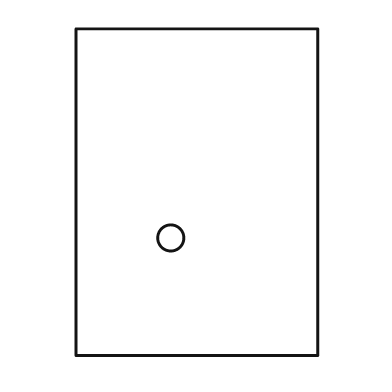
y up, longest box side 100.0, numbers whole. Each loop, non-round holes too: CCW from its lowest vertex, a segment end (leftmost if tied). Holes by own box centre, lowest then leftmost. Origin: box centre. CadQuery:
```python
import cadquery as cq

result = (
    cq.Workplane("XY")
    .moveTo(-37.0, -50.0)
    .lineTo(37.0, -50.0)
    .lineTo(37.0, 50.0)
    .lineTo(-37.0, 50.0)
    .close()
    .moveTo(-8.0, -14.0)
    .circle(4.0)
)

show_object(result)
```